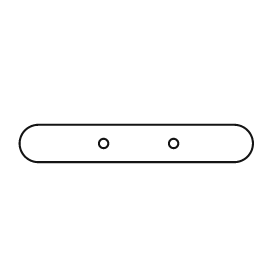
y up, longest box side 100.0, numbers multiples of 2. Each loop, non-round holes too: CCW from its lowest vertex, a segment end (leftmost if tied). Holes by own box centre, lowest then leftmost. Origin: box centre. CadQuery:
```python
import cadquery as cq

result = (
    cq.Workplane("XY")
    .moveTo(-42.0, -8.0)
    .lineTo(42.0, -8.0)
    .threePointArc((50.0, 0.0), (42.0, 8.0))
    .lineTo(-42.0, 8.0)
    .threePointArc((-50.0, 0.0), (-42.0, -8.0))
    .close()
    .moveTo(-14.0, 0.0)
    .circle(2.0)
    .moveTo(16.0, 0.0)
    .circle(2.0)
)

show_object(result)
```